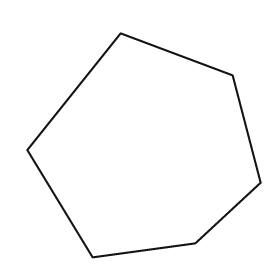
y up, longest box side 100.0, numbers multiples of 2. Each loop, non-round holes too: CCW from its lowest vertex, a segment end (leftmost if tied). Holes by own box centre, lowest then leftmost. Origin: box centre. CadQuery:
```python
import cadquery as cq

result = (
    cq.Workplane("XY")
    .moveTo(-22.0, -48.0)
    .lineTo(22.0, -42.0)
    .lineTo(50.0, -16.0)
    .lineTo(38.0, 30.0)
    .lineTo(-10.0, 48.0)
    .lineTo(-50.0, -2.0)
    .close()
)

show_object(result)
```